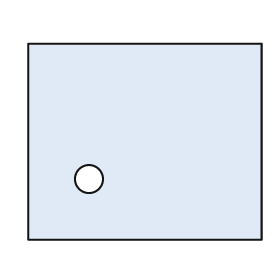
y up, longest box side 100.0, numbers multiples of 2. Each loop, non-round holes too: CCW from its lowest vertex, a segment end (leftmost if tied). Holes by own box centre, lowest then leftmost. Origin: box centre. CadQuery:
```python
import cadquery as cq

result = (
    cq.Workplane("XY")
    .moveTo(-50.0, -42.0)
    .lineTo(50.0, -42.0)
    .lineTo(50.0, 42.0)
    .lineTo(-50.0, 42.0)
    .close()
    .moveTo(-24.0, -16.0)
    .circle(6.0)
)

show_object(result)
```